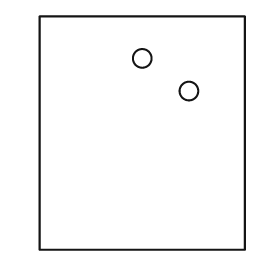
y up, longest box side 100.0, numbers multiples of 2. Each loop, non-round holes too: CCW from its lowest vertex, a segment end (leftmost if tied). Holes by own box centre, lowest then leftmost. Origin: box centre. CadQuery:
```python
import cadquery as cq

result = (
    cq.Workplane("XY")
    .moveTo(-44.0, -50.0)
    .lineTo(44.0, -50.0)
    .lineTo(44.0, 50.0)
    .lineTo(-44.0, 50.0)
    .close()
    .moveTo(20.0, 18.0)
    .circle(4.0)
    .moveTo(0.0, 32.0)
    .circle(4.0)
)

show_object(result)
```